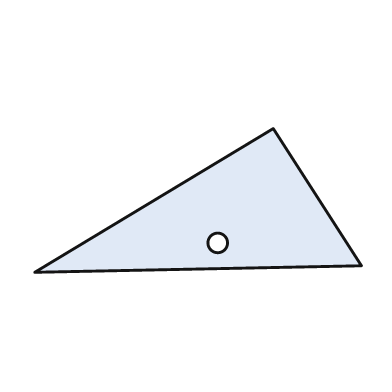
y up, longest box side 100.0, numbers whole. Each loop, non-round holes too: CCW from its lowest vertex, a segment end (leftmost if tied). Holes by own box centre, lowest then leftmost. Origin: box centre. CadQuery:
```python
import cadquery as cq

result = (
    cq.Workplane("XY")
    .moveTo(-50.0, -22.0)
    .lineTo(50.0, -20.0)
    .lineTo(23.0, 22.0)
    .close()
    .moveTo(6.0, -13.0)
    .circle(3.0)
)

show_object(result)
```